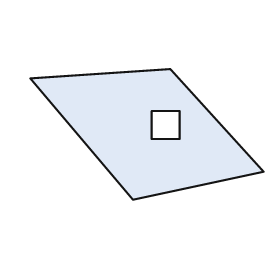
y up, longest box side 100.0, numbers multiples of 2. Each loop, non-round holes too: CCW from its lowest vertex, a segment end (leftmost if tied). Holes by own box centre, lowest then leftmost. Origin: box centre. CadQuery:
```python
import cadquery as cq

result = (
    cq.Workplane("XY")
    .moveTo(-6.0, -28.0)
    .lineTo(50.0, -16.0)
    .lineTo(10.0, 28.0)
    .lineTo(-50.0, 24.0)
    .close()
    .moveTo(2.0, -2.0)
    .lineTo(14.0, -2.0)
    .lineTo(14.0, 10.0)
    .lineTo(2.0, 10.0)
    .close()
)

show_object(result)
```